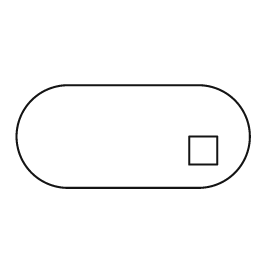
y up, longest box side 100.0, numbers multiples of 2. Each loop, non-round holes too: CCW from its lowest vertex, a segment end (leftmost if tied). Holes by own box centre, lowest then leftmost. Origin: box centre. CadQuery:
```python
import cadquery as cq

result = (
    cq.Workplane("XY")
    .moveTo(-28.0, -22.0)
    .lineTo(28.0, -22.0)
    .threePointArc((50.0, 0.0), (28.0, 22.0))
    .lineTo(-28.0, 22.0)
    .threePointArc((-50.0, 0.0), (-28.0, -22.0))
    .close()
    .moveTo(24.0, -12.0)
    .lineTo(36.0, -12.0)
    .lineTo(36.0, 0.0)
    .lineTo(24.0, 0.0)
    .close()
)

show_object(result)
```